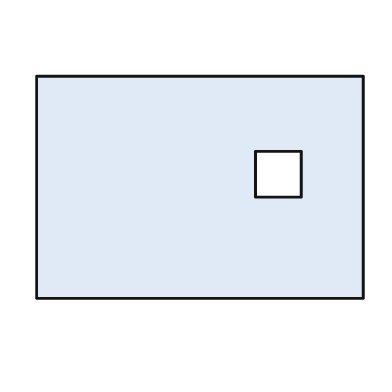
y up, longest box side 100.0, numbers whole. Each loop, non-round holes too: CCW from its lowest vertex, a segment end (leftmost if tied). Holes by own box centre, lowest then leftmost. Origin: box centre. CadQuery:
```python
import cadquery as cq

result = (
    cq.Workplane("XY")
    .moveTo(-50.0, -34.0)
    .lineTo(50.0, -34.0)
    .lineTo(50.0, 34.0)
    .lineTo(-50.0, 34.0)
    .close()
    .moveTo(17.0, -3.0)
    .lineTo(31.0, -3.0)
    .lineTo(31.0, 11.0)
    .lineTo(17.0, 11.0)
    .close()
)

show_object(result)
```